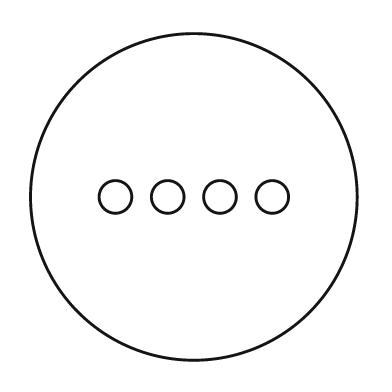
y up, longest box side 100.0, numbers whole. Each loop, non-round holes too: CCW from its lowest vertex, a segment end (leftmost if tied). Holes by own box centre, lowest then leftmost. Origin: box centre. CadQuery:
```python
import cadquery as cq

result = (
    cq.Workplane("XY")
    .moveTo(0.0, 0.0)
    .circle(50.0)
    .moveTo(-24.0, 0.0)
    .circle(5.0)
    .moveTo(-8.0, 0.0)
    .circle(5.0)
    .moveTo(8.0, 0.0)
    .circle(5.0)
    .moveTo(24.0, 0.0)
    .circle(5.0)
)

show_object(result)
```